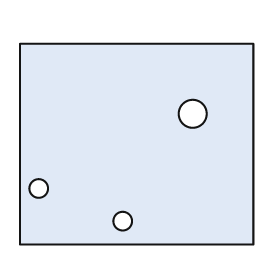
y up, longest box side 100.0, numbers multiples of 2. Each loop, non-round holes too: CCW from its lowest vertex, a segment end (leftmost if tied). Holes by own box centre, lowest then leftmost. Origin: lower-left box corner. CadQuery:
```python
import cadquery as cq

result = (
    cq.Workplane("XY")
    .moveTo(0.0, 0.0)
    .lineTo(100.0, 0.0)
    .lineTo(100.0, 86.0)
    .lineTo(0.0, 86.0)
    .close()
    .moveTo(44.0, 10.0)
    .circle(4.0)
    .moveTo(8.0, 24.0)
    .circle(4.0)
    .moveTo(74.0, 56.0)
    .circle(6.0)
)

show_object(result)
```